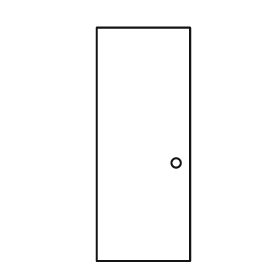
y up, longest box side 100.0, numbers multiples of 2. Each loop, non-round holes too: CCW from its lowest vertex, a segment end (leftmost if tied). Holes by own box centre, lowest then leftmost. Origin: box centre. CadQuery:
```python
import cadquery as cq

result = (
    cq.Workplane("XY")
    .moveTo(-20.0, -50.0)
    .lineTo(20.0, -50.0)
    .lineTo(20.0, 50.0)
    .lineTo(-20.0, 50.0)
    .close()
    .moveTo(14.0, -8.0)
    .circle(2.0)
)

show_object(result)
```